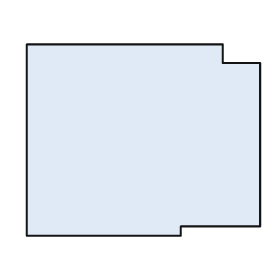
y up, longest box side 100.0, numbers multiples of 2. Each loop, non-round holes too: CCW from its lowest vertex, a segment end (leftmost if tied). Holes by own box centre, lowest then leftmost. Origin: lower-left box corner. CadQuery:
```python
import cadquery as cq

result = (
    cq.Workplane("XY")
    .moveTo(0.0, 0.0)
    .lineTo(66.0, 0.0)
    .lineTo(66.0, 4.0)
    .lineTo(100.0, 4.0)
    .lineTo(100.0, 74.0)
    .lineTo(84.0, 74.0)
    .lineTo(84.0, 82.0)
    .lineTo(0.0, 82.0)
    .close()
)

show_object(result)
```